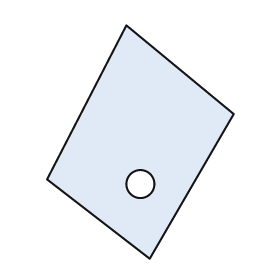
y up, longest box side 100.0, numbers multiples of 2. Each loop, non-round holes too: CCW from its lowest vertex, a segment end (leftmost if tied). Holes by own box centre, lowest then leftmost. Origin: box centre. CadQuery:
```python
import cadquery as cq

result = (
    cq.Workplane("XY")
    .moveTo(4.0, -50.0)
    .lineTo(40.0, 12.0)
    .lineTo(-6.0, 50.0)
    .lineTo(-40.0, -16.0)
    .close()
    .moveTo(0.0, -18.0)
    .circle(6.0)
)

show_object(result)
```